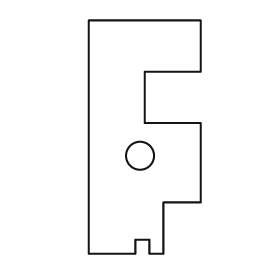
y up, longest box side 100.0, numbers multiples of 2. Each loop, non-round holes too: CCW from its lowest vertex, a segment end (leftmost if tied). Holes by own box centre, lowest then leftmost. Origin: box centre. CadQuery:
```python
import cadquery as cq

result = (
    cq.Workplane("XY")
    .moveTo(-24.0, -50.0)
    .lineTo(-4.0, -50.0)
    .lineTo(-4.0, -44.0)
    .lineTo(2.0, -44.0)
    .lineTo(2.0, -50.0)
    .lineTo(8.0, -50.0)
    .lineTo(8.0, -28.0)
    .lineTo(24.0, -28.0)
    .lineTo(24.0, 6.0)
    .lineTo(0.0, 6.0)
    .lineTo(0.0, 28.0)
    .lineTo(24.0, 28.0)
    .lineTo(24.0, 50.0)
    .lineTo(-24.0, 50.0)
    .close()
    .moveTo(-2.0, -8.0)
    .circle(6.0)
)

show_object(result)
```